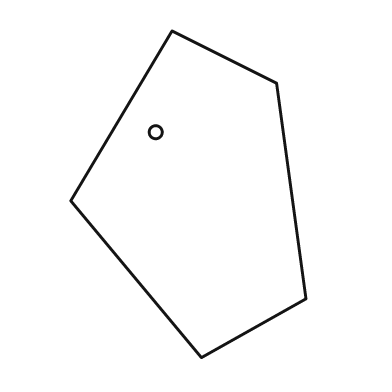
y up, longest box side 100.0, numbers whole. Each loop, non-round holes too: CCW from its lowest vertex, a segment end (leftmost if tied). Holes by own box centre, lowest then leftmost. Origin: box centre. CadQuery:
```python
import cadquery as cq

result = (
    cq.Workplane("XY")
    .moveTo(4.0, -50.0)
    .lineTo(36.0, -32.0)
    .lineTo(27.0, 34.0)
    .lineTo(-5.0, 50.0)
    .lineTo(-36.0, -2.0)
    .close()
    .moveTo(-10.0, 19.0)
    .circle(2.0)
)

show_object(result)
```